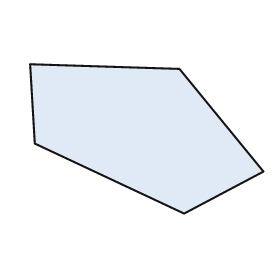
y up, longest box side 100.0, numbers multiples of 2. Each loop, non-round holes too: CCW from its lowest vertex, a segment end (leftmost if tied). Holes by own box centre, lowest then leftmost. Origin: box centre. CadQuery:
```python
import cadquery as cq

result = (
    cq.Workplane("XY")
    .moveTo(16.0, -32.0)
    .lineTo(50.0, -14.0)
    .lineTo(14.0, 30.0)
    .lineTo(-50.0, 32.0)
    .lineTo(-48.0, -2.0)
    .close()
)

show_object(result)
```